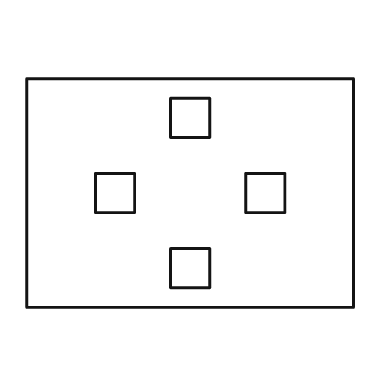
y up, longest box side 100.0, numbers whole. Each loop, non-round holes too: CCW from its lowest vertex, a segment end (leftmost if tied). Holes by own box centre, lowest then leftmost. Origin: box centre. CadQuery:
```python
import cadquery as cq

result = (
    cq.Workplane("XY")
    .moveTo(-50.0, -35.0)
    .lineTo(50.0, -35.0)
    .lineTo(50.0, 35.0)
    .lineTo(-50.0, 35.0)
    .close()
    .moveTo(-6.0, -29.0)
    .lineTo(6.0, -29.0)
    .lineTo(6.0, -17.0)
    .lineTo(-6.0, -17.0)
    .close()
    .moveTo(-29.0, -6.0)
    .lineTo(-17.0, -6.0)
    .lineTo(-17.0, 6.0)
    .lineTo(-29.0, 6.0)
    .close()
    .moveTo(17.0, -6.0)
    .lineTo(29.0, -6.0)
    .lineTo(29.0, 6.0)
    .lineTo(17.0, 6.0)
    .close()
    .moveTo(-6.0, 17.0)
    .lineTo(6.0, 17.0)
    .lineTo(6.0, 29.0)
    .lineTo(-6.0, 29.0)
    .close()
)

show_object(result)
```